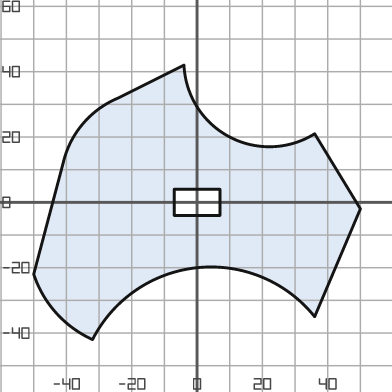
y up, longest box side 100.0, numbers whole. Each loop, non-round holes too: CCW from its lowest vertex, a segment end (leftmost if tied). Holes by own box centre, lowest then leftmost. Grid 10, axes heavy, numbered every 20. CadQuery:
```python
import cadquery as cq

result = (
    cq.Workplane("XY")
    .moveTo(-32.0, -42.0)
    .threePointArc((0.0, -20.0), (36.0, -35.0))
    .lineTo(50.0, -2.0)
    .lineTo(36.0, 21.0)
    .threePointArc((10.0, 20.0), (-4.0, 42.0))
    .lineTo(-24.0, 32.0)
    .threePointArc((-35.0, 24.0), (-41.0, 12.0))
    .lineTo(-50.0, -22.0)
    .threePointArc((-43.0, -34.0), (-32.0, -42.0))
    .close()
    .moveTo(-7.0, -4.0)
    .lineTo(7.0, -4.0)
    .lineTo(7.0, 4.0)
    .lineTo(-7.0, 4.0)
    .close()
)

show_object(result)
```